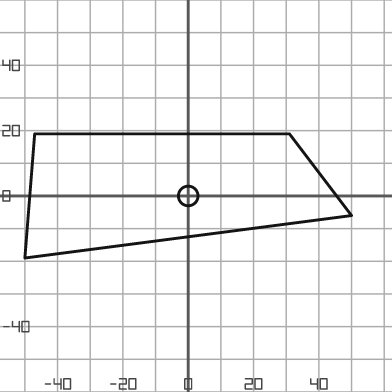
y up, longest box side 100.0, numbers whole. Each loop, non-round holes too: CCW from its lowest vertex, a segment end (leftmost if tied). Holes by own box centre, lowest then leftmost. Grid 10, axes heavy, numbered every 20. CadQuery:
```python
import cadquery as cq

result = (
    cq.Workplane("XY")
    .moveTo(-50.0, -19.0)
    .lineTo(50.0, -6.0)
    .lineTo(31.0, 19.0)
    .lineTo(-47.0, 19.0)
    .close()
    .moveTo(0.0, 0.0)
    .circle(3.0)
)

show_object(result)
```